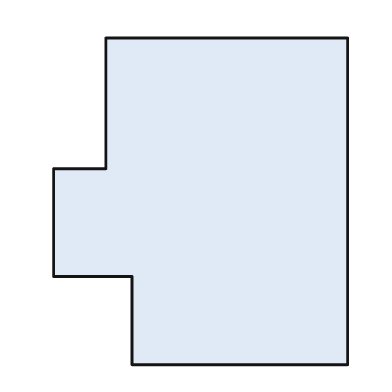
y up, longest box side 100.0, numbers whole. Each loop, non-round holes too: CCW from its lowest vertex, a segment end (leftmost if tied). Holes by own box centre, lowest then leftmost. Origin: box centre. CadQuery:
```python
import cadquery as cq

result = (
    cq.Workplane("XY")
    .moveTo(-21.0, -50.0)
    .lineTo(45.0, -50.0)
    .lineTo(45.0, 50.0)
    .lineTo(-29.0, 50.0)
    .lineTo(-29.0, 10.0)
    .lineTo(-45.0, 10.0)
    .lineTo(-45.0, -23.0)
    .lineTo(-21.0, -23.0)
    .close()
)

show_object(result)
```